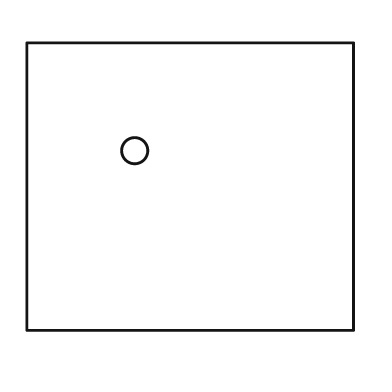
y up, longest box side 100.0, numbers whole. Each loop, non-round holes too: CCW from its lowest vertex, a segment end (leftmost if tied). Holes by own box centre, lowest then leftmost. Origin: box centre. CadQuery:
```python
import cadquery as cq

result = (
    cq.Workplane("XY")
    .moveTo(-50.0, -44.0)
    .lineTo(50.0, -44.0)
    .lineTo(50.0, 44.0)
    .lineTo(-50.0, 44.0)
    .close()
    .moveTo(-17.0, 11.0)
    .circle(4.0)
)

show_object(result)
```